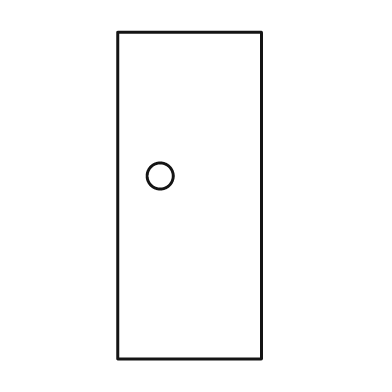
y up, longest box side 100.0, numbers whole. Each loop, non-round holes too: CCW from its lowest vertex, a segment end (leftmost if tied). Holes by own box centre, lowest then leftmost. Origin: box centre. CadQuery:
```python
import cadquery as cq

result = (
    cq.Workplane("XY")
    .moveTo(-22.0, -50.0)
    .lineTo(22.0, -50.0)
    .lineTo(22.0, 50.0)
    .lineTo(-22.0, 50.0)
    .close()
    .moveTo(-9.0, 6.0)
    .circle(4.0)
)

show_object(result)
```